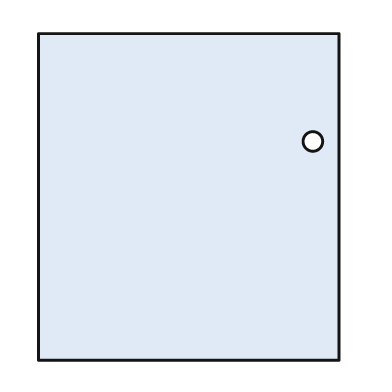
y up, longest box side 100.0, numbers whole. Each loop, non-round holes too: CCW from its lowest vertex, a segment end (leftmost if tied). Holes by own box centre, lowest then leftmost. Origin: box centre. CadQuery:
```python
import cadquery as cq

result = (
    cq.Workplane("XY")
    .moveTo(-46.0, -50.0)
    .lineTo(46.0, -50.0)
    .lineTo(46.0, 50.0)
    .lineTo(-46.0, 50.0)
    .close()
    .moveTo(38.0, 17.0)
    .circle(3.0)
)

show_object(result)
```